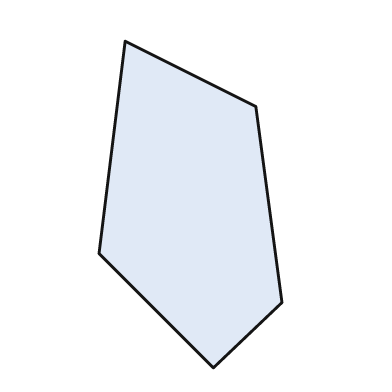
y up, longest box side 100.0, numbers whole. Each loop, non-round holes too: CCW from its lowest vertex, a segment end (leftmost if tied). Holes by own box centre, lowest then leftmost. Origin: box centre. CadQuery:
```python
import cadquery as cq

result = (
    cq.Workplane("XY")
    .moveTo(7.0, -50.0)
    .lineTo(28.0, -30.0)
    .lineTo(20.0, 30.0)
    .lineTo(-20.0, 50.0)
    .lineTo(-28.0, -15.0)
    .close()
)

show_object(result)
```